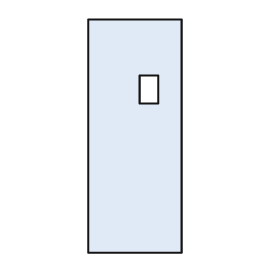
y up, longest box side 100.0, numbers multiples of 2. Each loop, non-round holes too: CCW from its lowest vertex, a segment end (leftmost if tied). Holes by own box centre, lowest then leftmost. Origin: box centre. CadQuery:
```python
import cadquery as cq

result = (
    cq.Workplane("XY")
    .moveTo(-20.0, -50.0)
    .lineTo(20.0, -50.0)
    .lineTo(20.0, 50.0)
    .lineTo(-20.0, 50.0)
    .close()
    .moveTo(2.0, 14.0)
    .lineTo(10.0, 14.0)
    .lineTo(10.0, 26.0)
    .lineTo(2.0, 26.0)
    .close()
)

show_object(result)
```